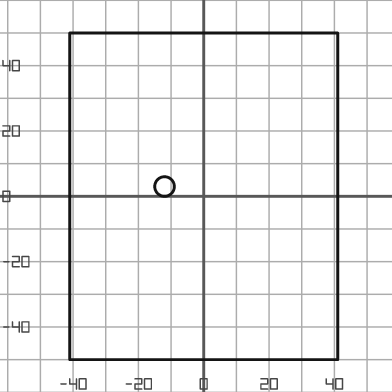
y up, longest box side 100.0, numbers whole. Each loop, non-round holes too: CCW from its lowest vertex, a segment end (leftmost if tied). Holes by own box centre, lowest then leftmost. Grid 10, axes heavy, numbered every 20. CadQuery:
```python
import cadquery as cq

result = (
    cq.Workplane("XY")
    .moveTo(-41.0, -50.0)
    .lineTo(41.0, -50.0)
    .lineTo(41.0, 50.0)
    .lineTo(-41.0, 50.0)
    .close()
    .moveTo(-12.0, 3.0)
    .circle(3.0)
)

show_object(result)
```